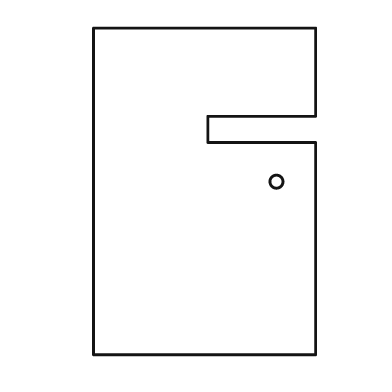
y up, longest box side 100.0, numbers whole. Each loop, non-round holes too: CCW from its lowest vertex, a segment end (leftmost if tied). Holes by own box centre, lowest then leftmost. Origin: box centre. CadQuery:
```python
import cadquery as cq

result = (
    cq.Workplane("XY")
    .moveTo(-34.0, -50.0)
    .lineTo(34.0, -50.0)
    .lineTo(34.0, 15.0)
    .lineTo(1.0, 15.0)
    .lineTo(1.0, 23.0)
    .lineTo(34.0, 23.0)
    .lineTo(34.0, 50.0)
    .lineTo(-34.0, 50.0)
    .close()
    .moveTo(22.0, 3.0)
    .circle(2.0)
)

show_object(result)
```